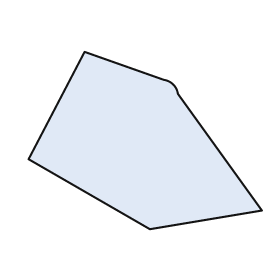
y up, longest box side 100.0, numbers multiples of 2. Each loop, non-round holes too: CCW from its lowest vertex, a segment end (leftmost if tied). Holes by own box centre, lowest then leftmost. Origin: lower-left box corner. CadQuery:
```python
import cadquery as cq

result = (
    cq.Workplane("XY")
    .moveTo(52.0, 0.0)
    .lineTo(100.0, 8.0)
    .lineTo(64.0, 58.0)
    .threePointArc((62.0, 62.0), (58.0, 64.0))
    .lineTo(24.0, 76.0)
    .lineTo(0.0, 30.0)
    .close()
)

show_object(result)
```